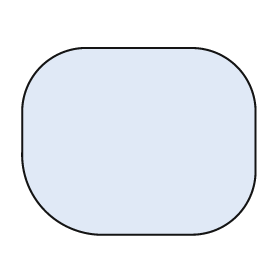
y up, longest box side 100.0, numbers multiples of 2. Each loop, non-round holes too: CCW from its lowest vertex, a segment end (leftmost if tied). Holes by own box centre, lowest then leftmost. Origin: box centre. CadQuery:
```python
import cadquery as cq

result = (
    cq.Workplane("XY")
    .moveTo(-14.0, -40.0)
    .lineTo(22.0, -40.0)
    .threePointArc((42.0, -32.0), (50.0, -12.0))
    .lineTo(50.0, 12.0)
    .threePointArc((42.0, 32.0), (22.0, 40.0))
    .lineTo(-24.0, 40.0)
    .threePointArc((-42.0, 32.0), (-50.0, 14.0))
    .lineTo(-50.0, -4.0)
    .threePointArc((-40.0, -30.0), (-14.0, -40.0))
    .close()
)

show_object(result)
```